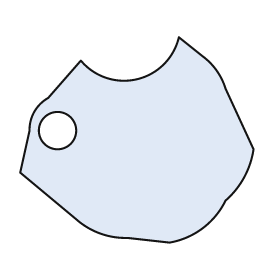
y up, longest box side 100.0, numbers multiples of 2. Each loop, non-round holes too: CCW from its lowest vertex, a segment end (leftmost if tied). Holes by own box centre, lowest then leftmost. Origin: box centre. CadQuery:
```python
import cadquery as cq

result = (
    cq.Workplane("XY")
    .moveTo(14.0, -44.0)
    .threePointArc((28.0, -38.0), (38.0, -26.0))
    .threePointArc((46.0, -16.0), (50.0, -4.0))
    .lineTo(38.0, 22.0)
    .threePointArc((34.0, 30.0), (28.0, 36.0))
    .lineTo(18.0, 44.0)
    .threePointArc((0.0, 26.0), (-24.0, 34.0))
    .lineTo(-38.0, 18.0)
    .threePointArc((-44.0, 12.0), (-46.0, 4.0))
    .lineTo(-50.0, -14.0)
    .lineTo(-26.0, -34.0)
    .threePointArc((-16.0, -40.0), (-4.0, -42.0))
    .close()
    .moveTo(-34.0, 4.0)
    .circle(8.0)
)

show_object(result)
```